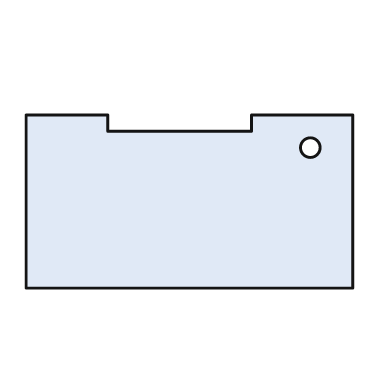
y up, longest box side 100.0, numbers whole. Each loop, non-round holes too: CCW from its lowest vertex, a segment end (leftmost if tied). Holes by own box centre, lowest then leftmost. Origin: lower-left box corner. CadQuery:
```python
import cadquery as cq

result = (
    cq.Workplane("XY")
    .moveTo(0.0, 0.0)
    .lineTo(100.0, 0.0)
    .lineTo(100.0, 53.0)
    .lineTo(69.0, 53.0)
    .lineTo(69.0, 48.0)
    .lineTo(25.0, 48.0)
    .lineTo(25.0, 53.0)
    .lineTo(0.0, 53.0)
    .close()
    .moveTo(87.0, 43.0)
    .circle(3.0)
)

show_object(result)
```